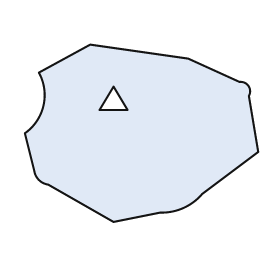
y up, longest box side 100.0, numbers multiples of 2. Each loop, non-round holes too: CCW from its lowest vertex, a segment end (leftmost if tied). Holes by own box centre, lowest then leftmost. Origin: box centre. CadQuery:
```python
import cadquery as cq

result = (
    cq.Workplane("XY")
    .moveTo(-12.0, -38.0)
    .lineTo(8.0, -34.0)
    .threePointArc((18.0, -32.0), (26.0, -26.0))
    .lineTo(50.0, -8.0)
    .lineTo(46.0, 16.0)
    .threePointArc((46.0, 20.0), (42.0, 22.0))
    .lineTo(20.0, 32.0)
    .lineTo(-22.0, 38.0)
    .lineTo(-44.0, 26.0)
    .threePointArc((-42.0, 12.0), (-50.0, 0.0))
    .lineTo(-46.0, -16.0)
    .threePointArc((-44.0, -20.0), (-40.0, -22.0))
    .close()
    .moveTo(-18.0, 10.0)
    .lineTo(-6.0, 10.0)
    .lineTo(-12.0, 20.0)
    .close()
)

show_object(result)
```